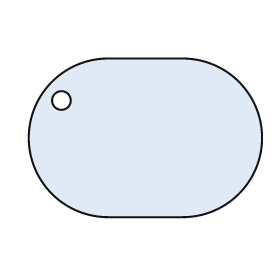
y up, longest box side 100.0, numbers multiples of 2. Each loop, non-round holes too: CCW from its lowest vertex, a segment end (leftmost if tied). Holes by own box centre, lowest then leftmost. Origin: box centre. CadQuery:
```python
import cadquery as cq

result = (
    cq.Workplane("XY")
    .moveTo(-16.0, -34.0)
    .lineTo(16.0, -34.0)
    .threePointArc((50.0, 0.0), (16.0, 34.0))
    .lineTo(-16.0, 34.0)
    .threePointArc((-50.0, 0.0), (-16.0, -34.0))
    .close()
    .moveTo(-36.0, 16.0)
    .circle(4.0)
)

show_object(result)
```